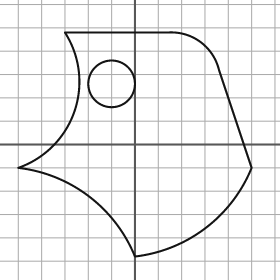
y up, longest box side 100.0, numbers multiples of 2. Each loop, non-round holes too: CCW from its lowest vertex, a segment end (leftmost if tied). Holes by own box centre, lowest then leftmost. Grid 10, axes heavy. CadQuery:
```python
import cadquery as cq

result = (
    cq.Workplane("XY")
    .moveTo(0.0, -48.0)
    .threePointArc((30.0, -36.0), (50.0, -10.0))
    .lineTo(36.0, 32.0)
    .threePointArc((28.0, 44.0), (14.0, 48.0))
    .lineTo(-30.0, 48.0)
    .threePointArc((-26.0, 14.0), (-50.0, -10.0))
    .threePointArc((-20.0, -22.0), (0.0, -48.0))
    .close()
    .moveTo(-10.0, 26.0)
    .circle(10.0)
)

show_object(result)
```